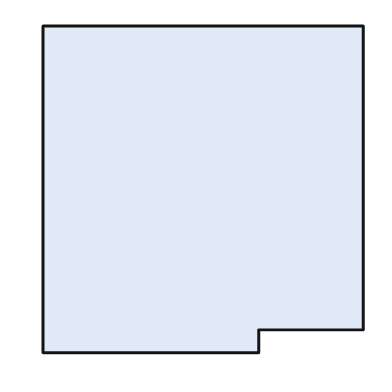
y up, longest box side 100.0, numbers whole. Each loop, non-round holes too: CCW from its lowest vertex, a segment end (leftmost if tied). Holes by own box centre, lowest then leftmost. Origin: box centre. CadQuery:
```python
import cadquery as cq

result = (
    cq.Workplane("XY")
    .moveTo(-49.0, -50.0)
    .lineTo(17.0, -50.0)
    .lineTo(17.0, -43.0)
    .lineTo(49.0, -43.0)
    .lineTo(49.0, 50.0)
    .lineTo(-49.0, 50.0)
    .close()
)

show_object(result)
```